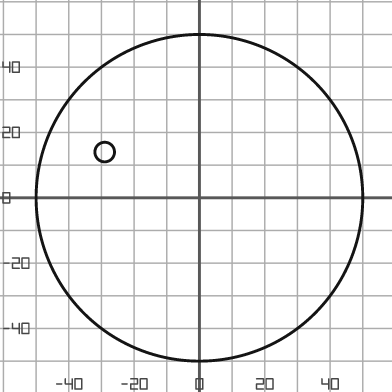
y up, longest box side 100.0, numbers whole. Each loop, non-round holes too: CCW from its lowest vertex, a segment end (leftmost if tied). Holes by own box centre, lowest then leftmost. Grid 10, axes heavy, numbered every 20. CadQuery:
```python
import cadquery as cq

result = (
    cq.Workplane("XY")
    .moveTo(0.0, 0.0)
    .circle(50.0)
    .moveTo(-29.0, 14.0)
    .circle(3.0)
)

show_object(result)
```